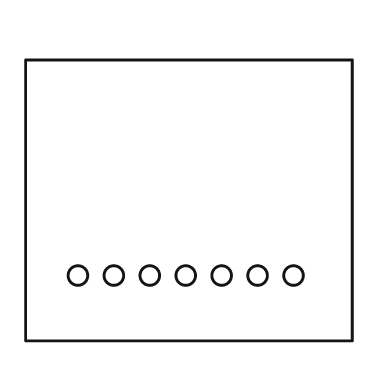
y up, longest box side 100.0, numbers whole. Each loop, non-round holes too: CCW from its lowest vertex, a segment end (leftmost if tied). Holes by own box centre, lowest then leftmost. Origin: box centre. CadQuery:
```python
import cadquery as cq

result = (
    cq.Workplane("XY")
    .moveTo(-50.0, -43.0)
    .lineTo(50.0, -43.0)
    .lineTo(50.0, 43.0)
    .lineTo(-50.0, 43.0)
    .close()
    .moveTo(-34.0, -23.0)
    .circle(3.0)
    .moveTo(-23.0, -23.0)
    .circle(3.0)
    .moveTo(-12.0, -23.0)
    .circle(3.0)
    .moveTo(-1.0, -23.0)
    .circle(3.0)
    .moveTo(10.0, -23.0)
    .circle(3.0)
    .moveTo(21.0, -23.0)
    .circle(3.0)
    .moveTo(32.0, -23.0)
    .circle(3.0)
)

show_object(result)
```